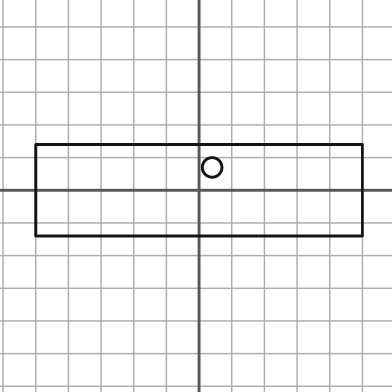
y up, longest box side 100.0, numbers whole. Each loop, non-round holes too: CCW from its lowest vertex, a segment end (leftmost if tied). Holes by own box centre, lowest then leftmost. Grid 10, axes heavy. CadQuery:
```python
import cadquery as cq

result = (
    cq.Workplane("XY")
    .moveTo(-50.0, -14.0)
    .lineTo(50.0, -14.0)
    .lineTo(50.0, 14.0)
    .lineTo(-50.0, 14.0)
    .close()
    .moveTo(4.0, 7.0)
    .circle(3.0)
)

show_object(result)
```